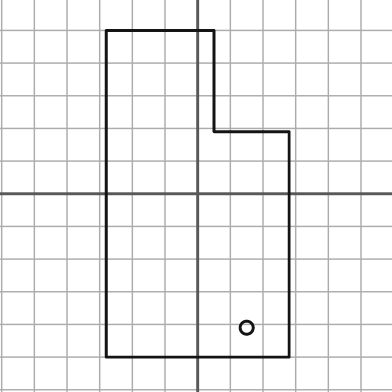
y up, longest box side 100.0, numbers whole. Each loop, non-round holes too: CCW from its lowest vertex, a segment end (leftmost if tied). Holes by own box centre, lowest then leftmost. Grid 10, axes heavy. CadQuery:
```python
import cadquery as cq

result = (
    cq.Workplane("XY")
    .moveTo(-28.0, -50.0)
    .lineTo(28.0, -50.0)
    .lineTo(28.0, 19.0)
    .lineTo(5.0, 19.0)
    .lineTo(5.0, 50.0)
    .lineTo(-28.0, 50.0)
    .close()
    .moveTo(15.0, -41.0)
    .circle(2.0)
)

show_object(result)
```